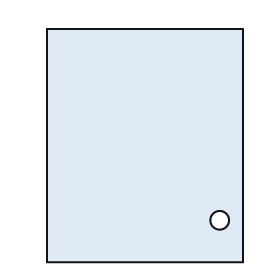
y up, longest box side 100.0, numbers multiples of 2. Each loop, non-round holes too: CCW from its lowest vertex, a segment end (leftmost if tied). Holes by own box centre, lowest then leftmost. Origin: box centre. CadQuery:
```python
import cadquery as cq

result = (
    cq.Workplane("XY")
    .moveTo(-42.0, -50.0)
    .lineTo(42.0, -50.0)
    .lineTo(42.0, 50.0)
    .lineTo(-42.0, 50.0)
    .close()
    .moveTo(32.0, -32.0)
    .circle(4.0)
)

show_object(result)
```